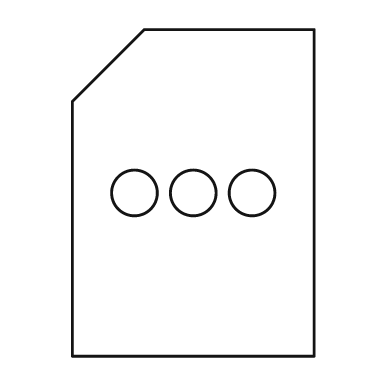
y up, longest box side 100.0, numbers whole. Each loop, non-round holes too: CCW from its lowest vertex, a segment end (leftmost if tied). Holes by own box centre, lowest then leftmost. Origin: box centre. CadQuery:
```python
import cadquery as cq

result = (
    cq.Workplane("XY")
    .moveTo(-37.0, -50.0)
    .lineTo(37.0, -50.0)
    .lineTo(37.0, 50.0)
    .lineTo(-15.0, 50.0)
    .lineTo(-37.0, 28.0)
    .close()
    .moveTo(-18.0, 0.0)
    .circle(7.0)
    .moveTo(0.0, 0.0)
    .circle(7.0)
    .moveTo(18.0, 0.0)
    .circle(7.0)
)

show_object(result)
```